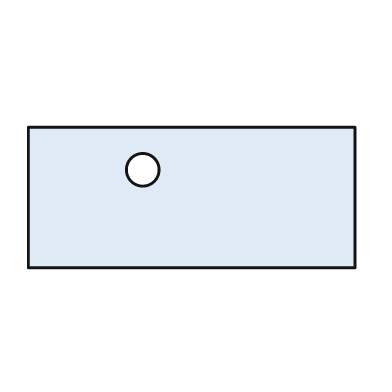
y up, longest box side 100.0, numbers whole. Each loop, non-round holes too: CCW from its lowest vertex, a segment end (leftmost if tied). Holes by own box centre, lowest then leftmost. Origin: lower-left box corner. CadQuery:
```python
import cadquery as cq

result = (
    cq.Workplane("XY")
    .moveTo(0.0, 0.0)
    .lineTo(100.0, 0.0)
    .lineTo(100.0, 43.0)
    .lineTo(0.0, 43.0)
    .close()
    .moveTo(35.0, 30.0)
    .circle(5.0)
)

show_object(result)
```